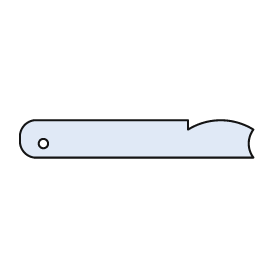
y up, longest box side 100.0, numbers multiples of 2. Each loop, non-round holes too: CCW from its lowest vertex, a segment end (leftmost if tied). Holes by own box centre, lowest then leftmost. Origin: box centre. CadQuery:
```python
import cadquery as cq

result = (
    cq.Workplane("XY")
    .moveTo(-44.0, -8.0)
    .lineTo(50.0, -8.0)
    .threePointArc((48.0, -2.0), (50.0, 4.0))
    .threePointArc((36.0, 8.0), (22.0, 4.0))
    .lineTo(22.0, 8.0)
    .lineTo(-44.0, 8.0)
    .threePointArc((-48.0, 6.0), (-50.0, 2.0))
    .lineTo(-50.0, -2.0)
    .threePointArc((-48.0, -6.0), (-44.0, -8.0))
    .close()
    .moveTo(-40.0, -2.0)
    .circle(2.0)
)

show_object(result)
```